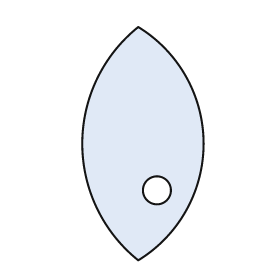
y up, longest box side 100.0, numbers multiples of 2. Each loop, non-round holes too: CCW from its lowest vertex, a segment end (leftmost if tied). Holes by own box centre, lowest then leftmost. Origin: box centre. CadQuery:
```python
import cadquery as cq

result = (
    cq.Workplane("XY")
    .moveTo(-2.0, -50.0)
    .threePointArc((26.0, 0.0), (-2.0, 50.0))
    .threePointArc((-26.0, 0.0), (-2.0, -50.0))
    .close()
    .moveTo(6.0, -20.0)
    .circle(6.0)
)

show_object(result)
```